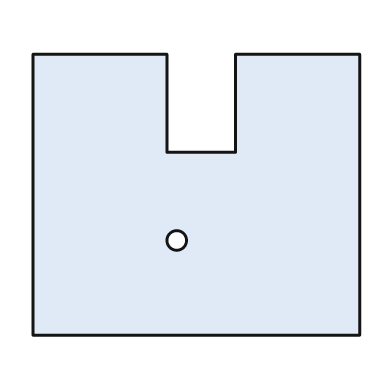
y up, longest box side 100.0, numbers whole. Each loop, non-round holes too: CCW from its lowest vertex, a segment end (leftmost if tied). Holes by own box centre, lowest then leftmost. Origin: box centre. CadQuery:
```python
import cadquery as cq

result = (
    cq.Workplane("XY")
    .moveTo(-50.0, -43.0)
    .lineTo(50.0, -43.0)
    .lineTo(50.0, 43.0)
    .lineTo(12.0, 43.0)
    .lineTo(12.0, 13.0)
    .lineTo(-9.0, 13.0)
    .lineTo(-9.0, 43.0)
    .lineTo(-50.0, 43.0)
    .close()
    .moveTo(-6.0, -14.0)
    .circle(3.0)
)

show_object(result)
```